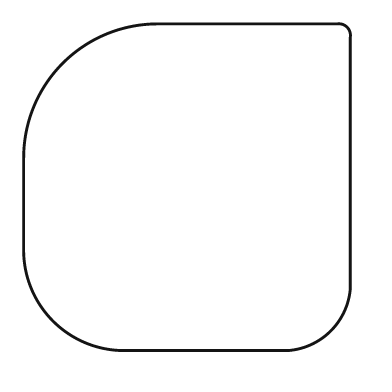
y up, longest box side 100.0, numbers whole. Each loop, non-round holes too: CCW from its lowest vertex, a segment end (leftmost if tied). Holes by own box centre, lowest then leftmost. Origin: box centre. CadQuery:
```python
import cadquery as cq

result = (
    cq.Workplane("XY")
    .moveTo(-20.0, -50.0)
    .lineTo(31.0, -50.0)
    .threePointArc((44.0, -44.0), (50.0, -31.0))
    .lineTo(50.0, 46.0)
    .threePointArc((49.0, 49.0), (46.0, 50.0))
    .lineTo(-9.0, 50.0)
    .threePointArc((-38.0, 38.0), (-50.0, 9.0))
    .lineTo(-50.0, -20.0)
    .threePointArc((-41.0, -41.0), (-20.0, -50.0))
    .close()
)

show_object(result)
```